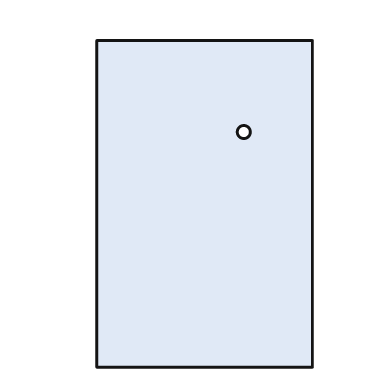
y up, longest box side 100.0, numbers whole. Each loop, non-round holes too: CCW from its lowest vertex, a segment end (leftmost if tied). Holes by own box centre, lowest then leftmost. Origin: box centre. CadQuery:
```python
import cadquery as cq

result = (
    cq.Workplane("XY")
    .moveTo(-33.0, -50.0)
    .lineTo(33.0, -50.0)
    .lineTo(33.0, 50.0)
    .lineTo(-33.0, 50.0)
    .close()
    .moveTo(12.0, 22.0)
    .circle(2.0)
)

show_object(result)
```